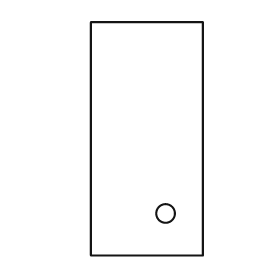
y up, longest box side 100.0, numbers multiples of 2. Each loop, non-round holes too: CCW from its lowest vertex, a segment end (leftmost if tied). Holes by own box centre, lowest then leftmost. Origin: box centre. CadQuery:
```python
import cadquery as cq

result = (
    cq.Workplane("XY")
    .moveTo(-24.0, -50.0)
    .lineTo(24.0, -50.0)
    .lineTo(24.0, 50.0)
    .lineTo(-24.0, 50.0)
    .close()
    .moveTo(8.0, -32.0)
    .circle(4.0)
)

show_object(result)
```